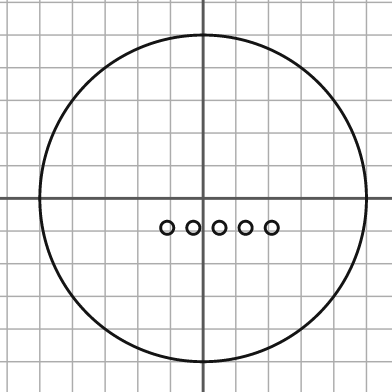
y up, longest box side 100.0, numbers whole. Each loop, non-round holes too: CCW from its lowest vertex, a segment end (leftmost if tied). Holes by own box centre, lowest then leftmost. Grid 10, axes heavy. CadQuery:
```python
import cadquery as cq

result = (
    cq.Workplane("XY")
    .moveTo(0.0, 0.0)
    .circle(50.0)
    .moveTo(-11.0, -9.0)
    .circle(2.0)
    .moveTo(-3.0, -9.0)
    .circle(2.0)
    .moveTo(5.0, -9.0)
    .circle(2.0)
    .moveTo(13.0, -9.0)
    .circle(2.0)
    .moveTo(21.0, -9.0)
    .circle(2.0)
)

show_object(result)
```